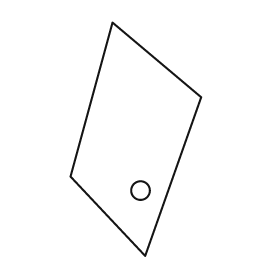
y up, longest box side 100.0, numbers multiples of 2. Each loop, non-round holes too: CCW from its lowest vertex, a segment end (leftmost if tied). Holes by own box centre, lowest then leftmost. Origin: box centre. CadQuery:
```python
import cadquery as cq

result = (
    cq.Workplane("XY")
    .moveTo(4.0, -50.0)
    .lineTo(28.0, 18.0)
    .lineTo(-10.0, 50.0)
    .lineTo(-28.0, -16.0)
    .close()
    .moveTo(2.0, -22.0)
    .circle(4.0)
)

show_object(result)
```